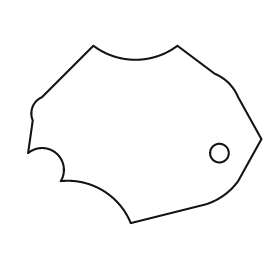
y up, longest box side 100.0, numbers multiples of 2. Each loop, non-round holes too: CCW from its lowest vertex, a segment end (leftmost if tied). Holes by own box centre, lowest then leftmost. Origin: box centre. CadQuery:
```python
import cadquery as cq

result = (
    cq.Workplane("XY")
    .moveTo(-6.0, -38.0)
    .lineTo(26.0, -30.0)
    .threePointArc((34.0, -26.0), (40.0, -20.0))
    .lineTo(50.0, -2.0)
    .lineTo(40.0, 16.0)
    .threePointArc((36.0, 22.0), (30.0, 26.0))
    .lineTo(14.0, 38.0)
    .threePointArc((-4.0, 32.0), (-22.0, 38.0))
    .lineTo(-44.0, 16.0)
    .threePointArc((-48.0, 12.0), (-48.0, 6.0))
    .lineTo(-50.0, -8.0)
    .threePointArc((-38.0, -8.0), (-36.0, -20.0))
    .threePointArc((-18.0, -24.0), (-6.0, -38.0))
    .close()
    .moveTo(32.0, -8.0)
    .circle(4.0)
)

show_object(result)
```